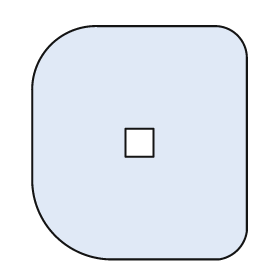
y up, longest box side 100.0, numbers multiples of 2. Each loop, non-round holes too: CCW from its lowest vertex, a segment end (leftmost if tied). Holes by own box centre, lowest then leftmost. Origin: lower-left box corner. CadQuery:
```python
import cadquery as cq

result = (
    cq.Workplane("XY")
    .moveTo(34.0, 0.0)
    .lineTo(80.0, 0.0)
    .threePointArc((88.0, 4.0), (92.0, 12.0))
    .lineTo(92.0, 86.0)
    .threePointArc((88.0, 96.0), (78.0, 100.0))
    .lineTo(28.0, 100.0)
    .threePointArc((8.0, 92.0), (0.0, 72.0))
    .lineTo(0.0, 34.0)
    .threePointArc((10.0, 10.0), (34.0, 0.0))
    .close()
    .moveTo(40.0, 44.0)
    .lineTo(52.0, 44.0)
    .lineTo(52.0, 56.0)
    .lineTo(40.0, 56.0)
    .close()
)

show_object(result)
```